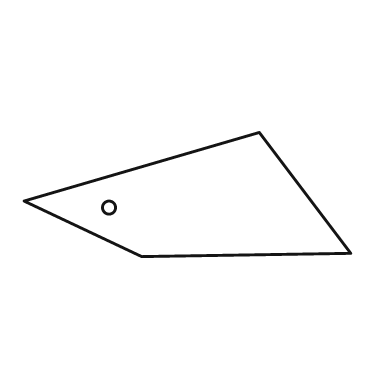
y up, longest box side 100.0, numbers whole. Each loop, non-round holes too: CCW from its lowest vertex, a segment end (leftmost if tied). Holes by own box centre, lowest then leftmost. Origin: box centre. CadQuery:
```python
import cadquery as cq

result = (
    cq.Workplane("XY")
    .moveTo(-14.0, -19.0)
    .lineTo(50.0, -18.0)
    .lineTo(22.0, 19.0)
    .lineTo(-50.0, -2.0)
    .close()
    .moveTo(-24.0, -4.0)
    .circle(2.0)
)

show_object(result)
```